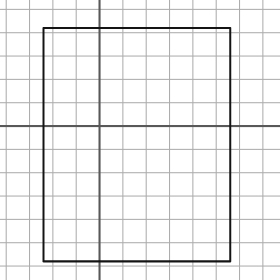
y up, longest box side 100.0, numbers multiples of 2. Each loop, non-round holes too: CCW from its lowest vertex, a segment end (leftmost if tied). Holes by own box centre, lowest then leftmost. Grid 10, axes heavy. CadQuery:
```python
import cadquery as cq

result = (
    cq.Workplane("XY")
    .moveTo(-24.0, -58.0)
    .lineTo(56.0, -58.0)
    .lineTo(56.0, 42.0)
    .lineTo(-24.0, 42.0)
    .close()
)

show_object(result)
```